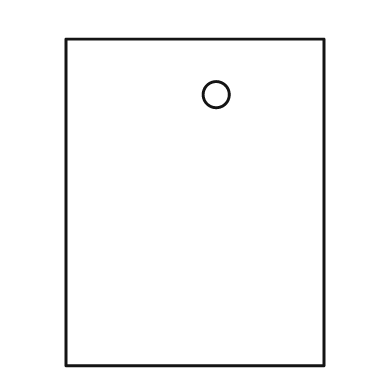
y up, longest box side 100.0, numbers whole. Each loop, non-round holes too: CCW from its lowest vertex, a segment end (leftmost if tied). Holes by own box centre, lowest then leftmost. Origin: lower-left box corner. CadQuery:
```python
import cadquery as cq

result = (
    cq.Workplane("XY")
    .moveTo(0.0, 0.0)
    .lineTo(79.0, 0.0)
    .lineTo(79.0, 100.0)
    .lineTo(0.0, 100.0)
    .close()
    .moveTo(46.0, 83.0)
    .circle(4.0)
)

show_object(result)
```